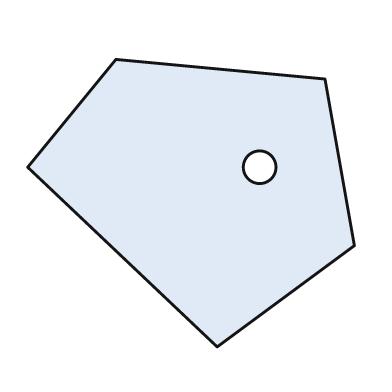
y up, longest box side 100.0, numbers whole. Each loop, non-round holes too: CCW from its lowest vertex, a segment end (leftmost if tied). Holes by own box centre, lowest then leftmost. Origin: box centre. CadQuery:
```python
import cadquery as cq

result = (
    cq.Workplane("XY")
    .moveTo(8.0, -44.0)
    .lineTo(50.0, -13.0)
    .lineTo(41.0, 38.0)
    .lineTo(-23.0, 44.0)
    .lineTo(-50.0, 11.0)
    .close()
    .moveTo(21.0, 11.0)
    .circle(5.0)
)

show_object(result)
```